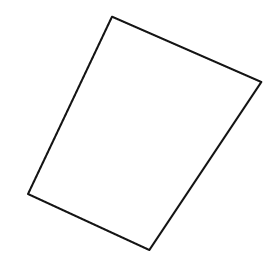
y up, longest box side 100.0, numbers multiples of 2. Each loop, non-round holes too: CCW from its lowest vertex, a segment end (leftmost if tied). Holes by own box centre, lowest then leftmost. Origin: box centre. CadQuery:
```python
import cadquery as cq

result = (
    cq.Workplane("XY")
    .moveTo(2.0, -50.0)
    .lineTo(50.0, 22.0)
    .lineTo(-14.0, 50.0)
    .lineTo(-50.0, -26.0)
    .close()
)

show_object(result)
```